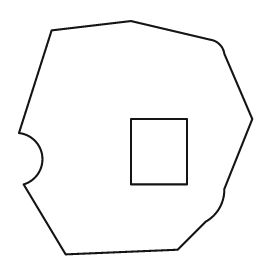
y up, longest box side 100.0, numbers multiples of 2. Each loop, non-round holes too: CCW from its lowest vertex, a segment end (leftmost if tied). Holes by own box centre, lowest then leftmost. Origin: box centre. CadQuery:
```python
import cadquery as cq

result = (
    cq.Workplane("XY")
    .moveTo(-30.0, -50.0)
    .lineTo(18.0, -48.0)
    .lineTo(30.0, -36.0)
    .threePointArc((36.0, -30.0), (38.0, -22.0))
    .lineTo(50.0, 8.0)
    .lineTo(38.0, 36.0)
    .threePointArc((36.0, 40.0), (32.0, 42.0))
    .lineTo(-2.0, 50.0)
    .lineTo(-36.0, 46.0)
    .lineTo(-50.0, 2.0)
    .threePointArc((-40.0, -8.0), (-48.0, -20.0))
    .close()
    .moveTo(-2.0, -20.0)
    .lineTo(22.0, -20.0)
    .lineTo(22.0, 8.0)
    .lineTo(-2.0, 8.0)
    .close()
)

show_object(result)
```